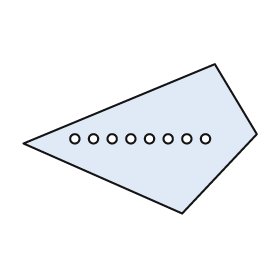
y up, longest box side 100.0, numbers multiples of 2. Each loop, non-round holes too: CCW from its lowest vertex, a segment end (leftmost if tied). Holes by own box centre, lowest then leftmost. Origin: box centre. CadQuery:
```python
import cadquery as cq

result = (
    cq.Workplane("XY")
    .moveTo(18.0, -32.0)
    .lineTo(50.0, 2.0)
    .lineTo(32.0, 32.0)
    .lineTo(-50.0, -2.0)
    .close()
    .moveTo(-28.0, 0.0)
    .circle(2.0)
    .moveTo(-20.0, 0.0)
    .circle(2.0)
    .moveTo(-12.0, 0.0)
    .circle(2.0)
    .moveTo(-4.0, 0.0)
    .circle(2.0)
    .moveTo(4.0, 0.0)
    .circle(2.0)
    .moveTo(12.0, 0.0)
    .circle(2.0)
    .moveTo(20.0, 0.0)
    .circle(2.0)
    .moveTo(28.0, 0.0)
    .circle(2.0)
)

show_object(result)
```